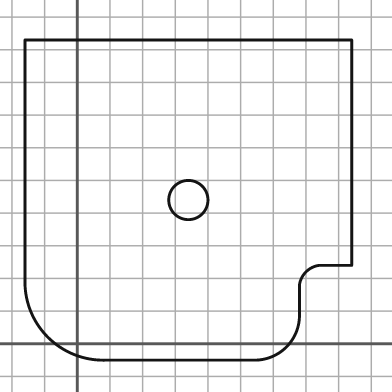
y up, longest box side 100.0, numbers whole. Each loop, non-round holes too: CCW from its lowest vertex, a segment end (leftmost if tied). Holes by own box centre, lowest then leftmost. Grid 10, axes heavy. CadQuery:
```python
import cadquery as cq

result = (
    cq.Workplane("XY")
    .moveTo(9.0, -5.0)
    .lineTo(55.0, -5.0)
    .threePointArc((64.0, -1.0), (68.0, 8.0))
    .lineTo(68.0, 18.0)
    .threePointArc((70.0, 22.0), (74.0, 24.0))
    .lineTo(84.0, 24.0)
    .lineTo(84.0, 93.0)
    .lineTo(-16.0, 93.0)
    .lineTo(-16.0, 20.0)
    .threePointArc((-9.0, 2.0), (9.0, -5.0))
    .close()
    .moveTo(34.0, 44.0)
    .circle(6.0)
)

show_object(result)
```